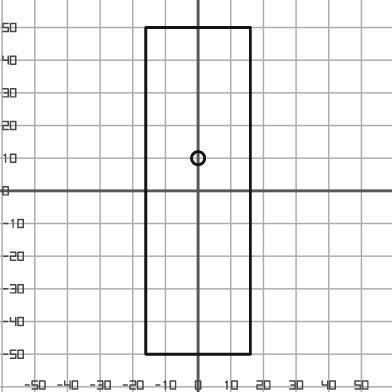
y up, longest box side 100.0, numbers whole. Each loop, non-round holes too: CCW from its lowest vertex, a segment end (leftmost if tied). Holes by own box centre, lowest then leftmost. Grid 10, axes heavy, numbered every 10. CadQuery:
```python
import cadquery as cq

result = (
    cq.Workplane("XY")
    .moveTo(-16.0, -50.0)
    .lineTo(16.0, -50.0)
    .lineTo(16.0, 50.0)
    .lineTo(-16.0, 50.0)
    .close()
    .moveTo(0.0, 10.0)
    .circle(2.0)
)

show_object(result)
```